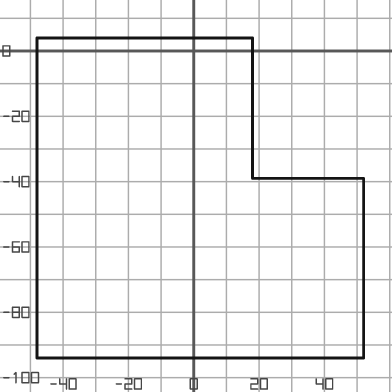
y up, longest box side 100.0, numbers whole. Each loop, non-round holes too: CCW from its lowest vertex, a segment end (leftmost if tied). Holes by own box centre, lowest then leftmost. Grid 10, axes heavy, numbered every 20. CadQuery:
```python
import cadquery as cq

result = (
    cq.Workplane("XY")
    .moveTo(-48.0, -94.0)
    .lineTo(52.0, -94.0)
    .lineTo(52.0, -39.0)
    .lineTo(18.0, -39.0)
    .lineTo(18.0, 4.0)
    .lineTo(-48.0, 4.0)
    .close()
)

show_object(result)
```